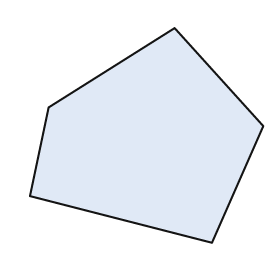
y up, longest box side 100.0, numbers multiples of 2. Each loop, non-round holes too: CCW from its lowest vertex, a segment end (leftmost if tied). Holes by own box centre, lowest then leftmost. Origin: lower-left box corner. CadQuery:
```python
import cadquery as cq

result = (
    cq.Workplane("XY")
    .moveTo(78.0, 0.0)
    .lineTo(100.0, 50.0)
    .lineTo(62.0, 92.0)
    .lineTo(8.0, 58.0)
    .lineTo(0.0, 20.0)
    .close()
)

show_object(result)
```